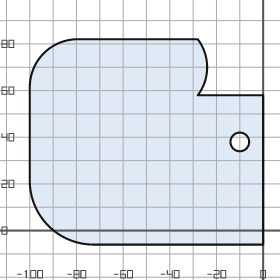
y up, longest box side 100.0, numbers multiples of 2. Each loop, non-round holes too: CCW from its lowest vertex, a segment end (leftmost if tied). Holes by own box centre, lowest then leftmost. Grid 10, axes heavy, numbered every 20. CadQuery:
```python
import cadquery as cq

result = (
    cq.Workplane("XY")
    .moveTo(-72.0, -6.0)
    .lineTo(0.0, -6.0)
    .lineTo(0.0, 58.0)
    .lineTo(-28.0, 58.0)
    .threePointArc((-24.0, 70.0), (-28.0, 82.0))
    .lineTo(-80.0, 82.0)
    .threePointArc((-94.0, 76.0), (-100.0, 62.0))
    .lineTo(-100.0, 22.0)
    .threePointArc((-92.0, 2.0), (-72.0, -6.0))
    .close()
    .moveTo(-10.0, 38.0)
    .circle(4.0)
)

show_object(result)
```